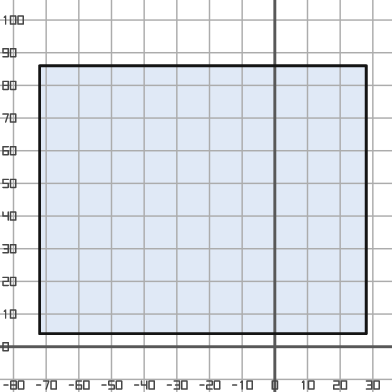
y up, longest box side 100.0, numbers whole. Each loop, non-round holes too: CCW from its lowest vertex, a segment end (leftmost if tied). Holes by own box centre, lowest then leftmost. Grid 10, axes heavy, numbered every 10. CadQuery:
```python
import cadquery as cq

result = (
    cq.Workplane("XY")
    .moveTo(-72.0, 4.0)
    .lineTo(28.0, 4.0)
    .lineTo(28.0, 86.0)
    .lineTo(-72.0, 86.0)
    .close()
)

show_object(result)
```